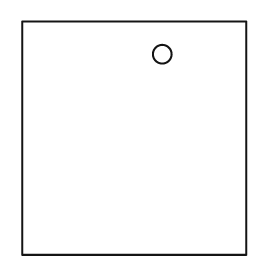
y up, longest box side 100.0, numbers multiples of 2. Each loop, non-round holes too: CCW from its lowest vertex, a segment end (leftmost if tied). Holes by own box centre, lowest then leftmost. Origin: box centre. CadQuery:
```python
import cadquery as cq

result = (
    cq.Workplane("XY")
    .moveTo(-48.0, -50.0)
    .lineTo(48.0, -50.0)
    .lineTo(48.0, 50.0)
    .lineTo(-48.0, 50.0)
    .close()
    .moveTo(12.0, 36.0)
    .circle(4.0)
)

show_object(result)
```